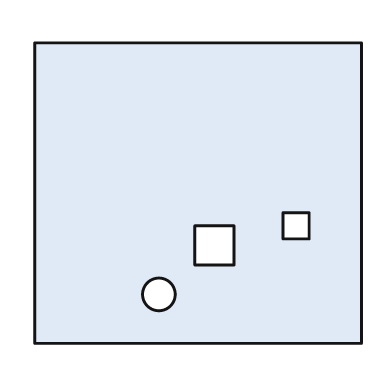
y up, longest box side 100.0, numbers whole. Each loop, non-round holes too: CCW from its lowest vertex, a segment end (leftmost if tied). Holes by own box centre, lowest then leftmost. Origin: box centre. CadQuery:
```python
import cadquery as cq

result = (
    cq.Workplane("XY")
    .moveTo(-50.0, -46.0)
    .lineTo(50.0, -46.0)
    .lineTo(50.0, 46.0)
    .lineTo(-50.0, 46.0)
    .close()
    .moveTo(-12.0, -31.0)
    .circle(5.0)
    .moveTo(-1.0, -22.0)
    .lineTo(11.0, -22.0)
    .lineTo(11.0, -10.0)
    .lineTo(-1.0, -10.0)
    .close()
    .moveTo(26.0, -14.0)
    .lineTo(34.0, -14.0)
    .lineTo(34.0, -6.0)
    .lineTo(26.0, -6.0)
    .close()
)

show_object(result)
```